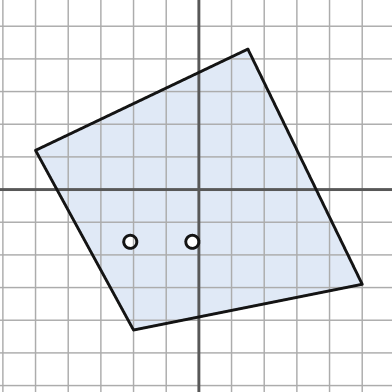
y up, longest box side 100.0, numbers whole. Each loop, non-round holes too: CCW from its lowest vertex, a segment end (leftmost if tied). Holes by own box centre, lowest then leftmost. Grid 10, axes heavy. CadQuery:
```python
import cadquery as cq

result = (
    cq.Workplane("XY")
    .moveTo(-20.0, -43.0)
    .lineTo(50.0, -29.0)
    .lineTo(15.0, 43.0)
    .lineTo(-50.0, 12.0)
    .close()
    .moveTo(-21.0, -16.0)
    .circle(2.0)
    .moveTo(-2.0, -16.0)
    .circle(2.0)
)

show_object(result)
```